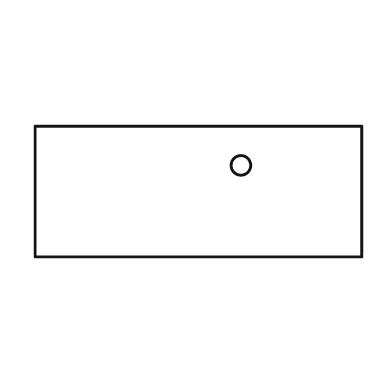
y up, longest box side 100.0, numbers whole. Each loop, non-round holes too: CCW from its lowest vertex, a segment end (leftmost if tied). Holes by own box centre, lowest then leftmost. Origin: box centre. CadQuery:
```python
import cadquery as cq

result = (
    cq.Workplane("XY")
    .moveTo(-50.0, -20.0)
    .lineTo(50.0, -20.0)
    .lineTo(50.0, 20.0)
    .lineTo(-50.0, 20.0)
    .close()
    .moveTo(13.0, 8.0)
    .circle(3.0)
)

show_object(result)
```